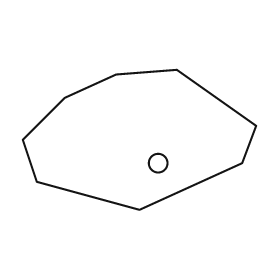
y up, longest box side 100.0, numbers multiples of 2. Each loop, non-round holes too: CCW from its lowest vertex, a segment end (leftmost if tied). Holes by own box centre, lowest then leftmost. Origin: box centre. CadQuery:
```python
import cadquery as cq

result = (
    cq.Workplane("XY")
    .moveTo(0.0, -30.0)
    .lineTo(44.0, -10.0)
    .lineTo(50.0, 6.0)
    .lineTo(16.0, 30.0)
    .lineTo(-10.0, 28.0)
    .lineTo(-32.0, 18.0)
    .lineTo(-50.0, 0.0)
    .lineTo(-44.0, -18.0)
    .close()
    .moveTo(8.0, -10.0)
    .circle(4.0)
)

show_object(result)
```